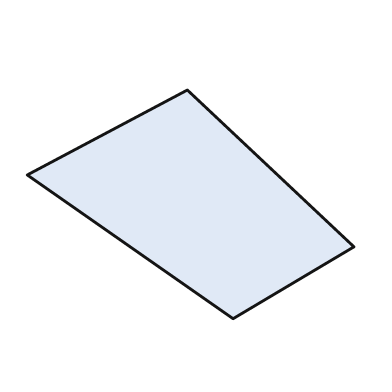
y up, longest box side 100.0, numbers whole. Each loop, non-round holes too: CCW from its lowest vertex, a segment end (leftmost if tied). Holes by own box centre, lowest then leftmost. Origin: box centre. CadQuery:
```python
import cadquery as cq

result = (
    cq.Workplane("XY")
    .moveTo(13.0, -35.0)
    .lineTo(50.0, -13.0)
    .lineTo(-1.0, 35.0)
    .lineTo(-50.0, 9.0)
    .close()
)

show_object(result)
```